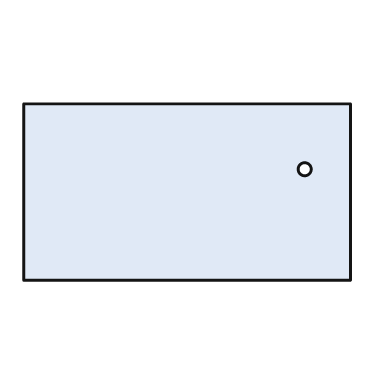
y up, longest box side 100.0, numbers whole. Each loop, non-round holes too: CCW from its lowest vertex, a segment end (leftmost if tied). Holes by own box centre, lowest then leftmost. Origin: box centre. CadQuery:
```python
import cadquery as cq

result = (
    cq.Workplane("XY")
    .moveTo(-50.0, -27.0)
    .lineTo(50.0, -27.0)
    .lineTo(50.0, 27.0)
    .lineTo(-50.0, 27.0)
    .close()
    .moveTo(36.0, 7.0)
    .circle(2.0)
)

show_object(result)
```